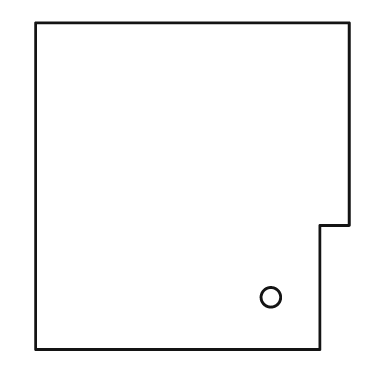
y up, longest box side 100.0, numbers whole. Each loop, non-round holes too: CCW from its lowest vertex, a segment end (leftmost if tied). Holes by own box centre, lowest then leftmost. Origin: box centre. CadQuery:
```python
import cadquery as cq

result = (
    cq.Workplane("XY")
    .moveTo(-48.0, -50.0)
    .lineTo(39.0, -50.0)
    .lineTo(39.0, -12.0)
    .lineTo(48.0, -12.0)
    .lineTo(48.0, 50.0)
    .lineTo(-48.0, 50.0)
    .close()
    .moveTo(24.0, -34.0)
    .circle(3.0)
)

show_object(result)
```